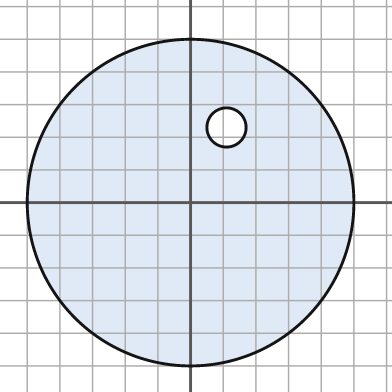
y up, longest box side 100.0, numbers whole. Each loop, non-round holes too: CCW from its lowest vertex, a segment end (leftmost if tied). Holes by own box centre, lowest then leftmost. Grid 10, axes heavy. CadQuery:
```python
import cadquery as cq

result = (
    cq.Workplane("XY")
    .moveTo(0.0, 0.0)
    .circle(50.0)
    .moveTo(11.0, 23.0)
    .circle(6.0)
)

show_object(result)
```